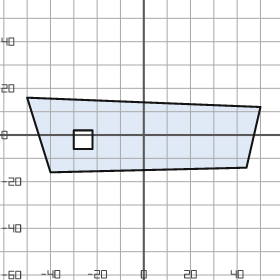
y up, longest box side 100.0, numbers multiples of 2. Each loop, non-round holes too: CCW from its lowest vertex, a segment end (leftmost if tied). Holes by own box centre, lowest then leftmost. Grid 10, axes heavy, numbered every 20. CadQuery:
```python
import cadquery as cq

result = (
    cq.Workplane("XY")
    .moveTo(-40.0, -16.0)
    .lineTo(44.0, -14.0)
    .lineTo(50.0, 12.0)
    .lineTo(-50.0, 16.0)
    .close()
    .moveTo(-30.0, -6.0)
    .lineTo(-22.0, -6.0)
    .lineTo(-22.0, 2.0)
    .lineTo(-30.0, 2.0)
    .close()
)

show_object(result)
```